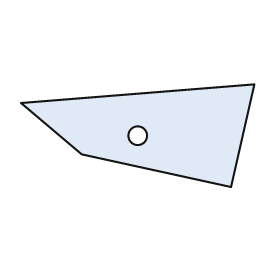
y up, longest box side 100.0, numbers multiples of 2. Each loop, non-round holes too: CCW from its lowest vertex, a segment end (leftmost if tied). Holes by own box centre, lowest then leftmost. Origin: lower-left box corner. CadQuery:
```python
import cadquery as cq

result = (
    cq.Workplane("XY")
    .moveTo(90.0, 0.0)
    .lineTo(100.0, 44.0)
    .lineTo(0.0, 36.0)
    .lineTo(26.0, 14.0)
    .close()
    .moveTo(50.0, 22.0)
    .circle(4.0)
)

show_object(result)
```